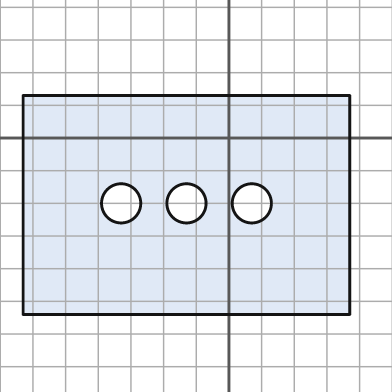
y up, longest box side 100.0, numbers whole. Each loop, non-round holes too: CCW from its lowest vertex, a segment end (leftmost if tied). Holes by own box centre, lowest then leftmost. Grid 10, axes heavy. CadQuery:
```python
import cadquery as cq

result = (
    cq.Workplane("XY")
    .moveTo(-63.0, -54.0)
    .lineTo(37.0, -54.0)
    .lineTo(37.0, 13.0)
    .lineTo(-63.0, 13.0)
    .close()
    .moveTo(-33.0, -20.0)
    .circle(6.0)
    .moveTo(-13.0, -20.0)
    .circle(6.0)
    .moveTo(7.0, -20.0)
    .circle(6.0)
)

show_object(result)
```